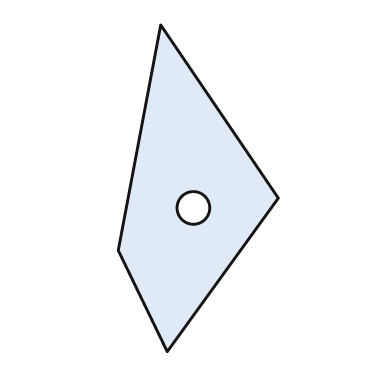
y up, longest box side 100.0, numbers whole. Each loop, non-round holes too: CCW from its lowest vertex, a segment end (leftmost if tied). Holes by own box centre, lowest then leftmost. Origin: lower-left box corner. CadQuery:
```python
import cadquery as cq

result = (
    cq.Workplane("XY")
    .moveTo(15.0, 0.0)
    .lineTo(49.0, 47.0)
    .lineTo(13.0, 100.0)
    .lineTo(0.0, 31.0)
    .close()
    .moveTo(23.0, 44.0)
    .circle(5.0)
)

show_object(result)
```